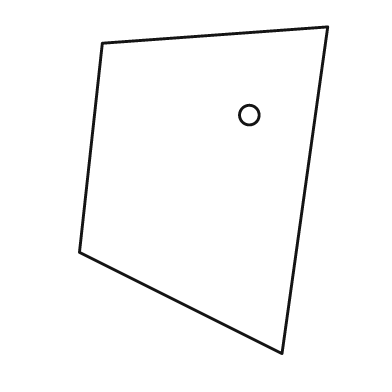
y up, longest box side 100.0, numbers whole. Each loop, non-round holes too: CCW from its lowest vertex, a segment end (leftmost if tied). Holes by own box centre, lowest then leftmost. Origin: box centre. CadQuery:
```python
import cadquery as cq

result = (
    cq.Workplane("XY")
    .moveTo(24.0, -50.0)
    .lineTo(38.0, 50.0)
    .lineTo(-31.0, 45.0)
    .lineTo(-38.0, -19.0)
    .close()
    .moveTo(14.0, 23.0)
    .circle(3.0)
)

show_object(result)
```